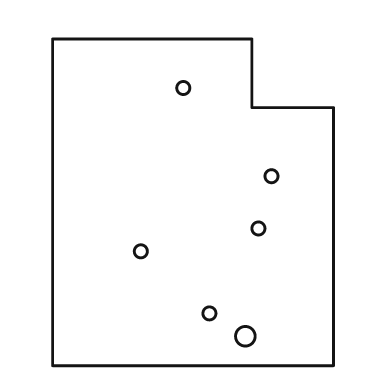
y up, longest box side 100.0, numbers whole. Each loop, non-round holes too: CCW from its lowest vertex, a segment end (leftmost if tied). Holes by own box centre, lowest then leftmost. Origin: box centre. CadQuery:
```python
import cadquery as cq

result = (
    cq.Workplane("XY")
    .moveTo(-43.0, -50.0)
    .lineTo(43.0, -50.0)
    .lineTo(43.0, 29.0)
    .lineTo(18.0, 29.0)
    .lineTo(18.0, 50.0)
    .lineTo(-43.0, 50.0)
    .close()
    .moveTo(16.0, -41.0)
    .circle(3.0)
    .moveTo(5.0, -34.0)
    .circle(2.0)
    .moveTo(-16.0, -15.0)
    .circle(2.0)
    .moveTo(20.0, -8.0)
    .circle(2.0)
    .moveTo(24.0, 8.0)
    .circle(2.0)
    .moveTo(-3.0, 35.0)
    .circle(2.0)
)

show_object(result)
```